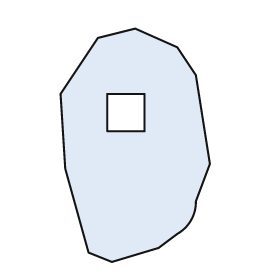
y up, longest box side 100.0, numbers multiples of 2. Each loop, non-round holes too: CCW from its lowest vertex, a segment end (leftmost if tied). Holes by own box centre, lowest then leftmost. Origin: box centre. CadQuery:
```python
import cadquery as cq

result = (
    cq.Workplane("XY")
    .moveTo(-10.0, -50.0)
    .lineTo(10.0, -44.0)
    .lineTo(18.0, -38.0)
    .threePointArc((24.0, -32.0), (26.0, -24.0))
    .lineTo(32.0, -8.0)
    .lineTo(26.0, 30.0)
    .lineTo(18.0, 42.0)
    .lineTo(0.0, 50.0)
    .lineTo(-16.0, 46.0)
    .lineTo(-32.0, 22.0)
    .lineTo(-30.0, -10.0)
    .lineTo(-20.0, -46.0)
    .close()
    .moveTo(-12.0, 6.0)
    .lineTo(4.0, 6.0)
    .lineTo(4.0, 22.0)
    .lineTo(-12.0, 22.0)
    .close()
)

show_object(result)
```